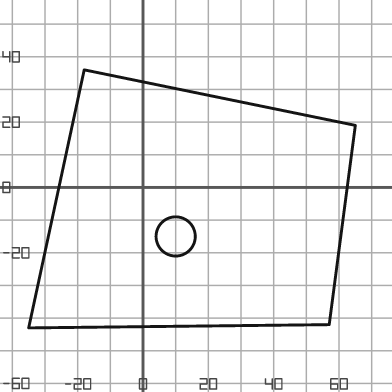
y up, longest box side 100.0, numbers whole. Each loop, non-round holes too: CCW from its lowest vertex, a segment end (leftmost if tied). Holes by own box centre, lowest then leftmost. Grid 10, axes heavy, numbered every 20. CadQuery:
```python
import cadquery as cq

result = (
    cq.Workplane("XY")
    .moveTo(-35.0, -43.0)
    .lineTo(57.0, -42.0)
    .lineTo(65.0, 19.0)
    .lineTo(-18.0, 36.0)
    .close()
    .moveTo(10.0, -15.0)
    .circle(6.0)
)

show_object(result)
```